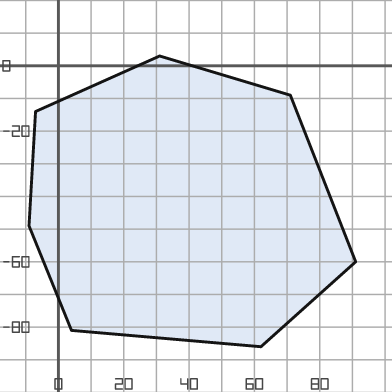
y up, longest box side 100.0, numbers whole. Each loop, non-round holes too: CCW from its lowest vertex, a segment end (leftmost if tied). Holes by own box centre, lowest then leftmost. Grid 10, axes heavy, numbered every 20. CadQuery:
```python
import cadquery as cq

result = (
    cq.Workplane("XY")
    .moveTo(62.0, -86.0)
    .lineTo(91.0, -60.0)
    .lineTo(71.0, -9.0)
    .lineTo(31.0, 3.0)
    .lineTo(-7.0, -14.0)
    .lineTo(-9.0, -49.0)
    .lineTo(4.0, -81.0)
    .close()
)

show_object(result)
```